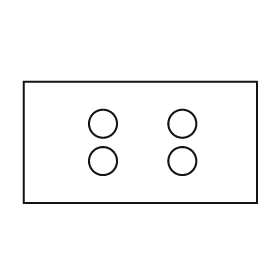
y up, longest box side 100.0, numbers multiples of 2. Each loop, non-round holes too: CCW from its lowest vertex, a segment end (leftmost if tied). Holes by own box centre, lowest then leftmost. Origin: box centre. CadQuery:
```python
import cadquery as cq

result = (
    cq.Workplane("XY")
    .moveTo(-50.0, -26.0)
    .lineTo(50.0, -26.0)
    .lineTo(50.0, 26.0)
    .lineTo(-50.0, 26.0)
    .close()
    .moveTo(-16.0, -8.0)
    .circle(6.0)
    .moveTo(18.0, -8.0)
    .circle(6.0)
    .moveTo(-16.0, 8.0)
    .circle(6.0)
    .moveTo(18.0, 8.0)
    .circle(6.0)
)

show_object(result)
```